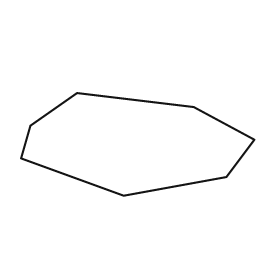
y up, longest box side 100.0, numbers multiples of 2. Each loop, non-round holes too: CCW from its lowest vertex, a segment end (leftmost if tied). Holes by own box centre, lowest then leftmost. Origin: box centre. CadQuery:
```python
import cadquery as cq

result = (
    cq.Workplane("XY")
    .moveTo(-6.0, -22.0)
    .lineTo(38.0, -14.0)
    .lineTo(50.0, 2.0)
    .lineTo(24.0, 16.0)
    .lineTo(-26.0, 22.0)
    .lineTo(-46.0, 8.0)
    .lineTo(-50.0, -6.0)
    .close()
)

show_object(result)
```